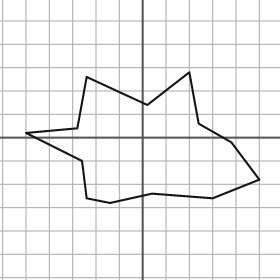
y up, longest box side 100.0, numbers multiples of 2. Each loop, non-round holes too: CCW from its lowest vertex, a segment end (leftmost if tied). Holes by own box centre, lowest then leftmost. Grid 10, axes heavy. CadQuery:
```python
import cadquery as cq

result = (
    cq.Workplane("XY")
    .moveTo(-14.0, -28.0)
    .lineTo(4.0, -24.0)
    .lineTo(30.0, -26.0)
    .lineTo(50.0, -18.0)
    .lineTo(38.0, -2.0)
    .lineTo(24.0, 6.0)
    .lineTo(20.0, 28.0)
    .lineTo(2.0, 14.0)
    .lineTo(-24.0, 26.0)
    .lineTo(-28.0, 4.0)
    .lineTo(-50.0, 2.0)
    .lineTo(-26.0, -10.0)
    .lineTo(-24.0, -26.0)
    .close()
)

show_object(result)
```